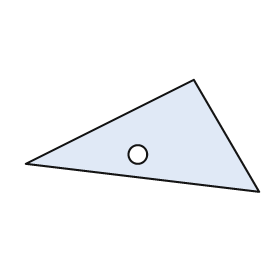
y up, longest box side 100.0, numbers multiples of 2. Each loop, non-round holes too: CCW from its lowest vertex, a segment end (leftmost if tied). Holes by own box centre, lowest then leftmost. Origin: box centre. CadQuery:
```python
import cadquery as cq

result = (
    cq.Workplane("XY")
    .moveTo(50.0, -24.0)
    .lineTo(22.0, 24.0)
    .lineTo(-50.0, -12.0)
    .close()
    .moveTo(-2.0, -8.0)
    .circle(4.0)
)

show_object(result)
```